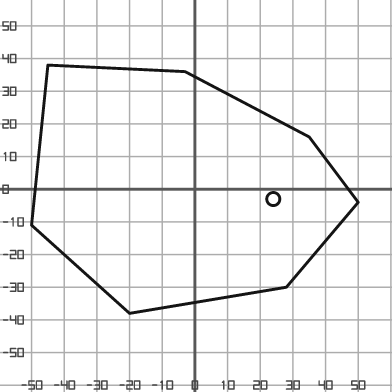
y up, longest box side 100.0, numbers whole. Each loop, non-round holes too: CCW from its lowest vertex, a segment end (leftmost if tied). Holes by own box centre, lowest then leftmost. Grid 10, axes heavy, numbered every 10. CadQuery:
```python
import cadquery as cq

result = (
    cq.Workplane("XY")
    .moveTo(-20.0, -38.0)
    .lineTo(28.0, -30.0)
    .lineTo(50.0, -4.0)
    .lineTo(35.0, 16.0)
    .lineTo(-3.0, 36.0)
    .lineTo(-45.0, 38.0)
    .lineTo(-50.0, -11.0)
    .close()
    .moveTo(24.0, -3.0)
    .circle(2.0)
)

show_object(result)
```